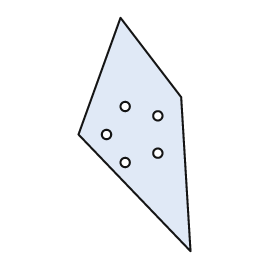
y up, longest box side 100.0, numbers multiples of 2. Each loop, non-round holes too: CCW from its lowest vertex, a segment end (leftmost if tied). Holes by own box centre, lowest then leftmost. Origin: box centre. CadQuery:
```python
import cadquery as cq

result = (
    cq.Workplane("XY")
    .moveTo(24.0, -50.0)
    .lineTo(20.0, 16.0)
    .lineTo(-6.0, 50.0)
    .lineTo(-24.0, 0.0)
    .close()
    .moveTo(-4.0, -12.0)
    .circle(2.0)
    .moveTo(10.0, -8.0)
    .circle(2.0)
    .moveTo(-12.0, 0.0)
    .circle(2.0)
    .moveTo(10.0, 8.0)
    .circle(2.0)
    .moveTo(-4.0, 12.0)
    .circle(2.0)
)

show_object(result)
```